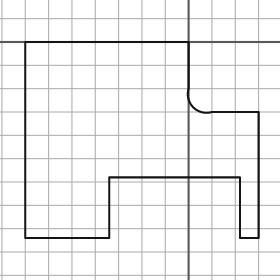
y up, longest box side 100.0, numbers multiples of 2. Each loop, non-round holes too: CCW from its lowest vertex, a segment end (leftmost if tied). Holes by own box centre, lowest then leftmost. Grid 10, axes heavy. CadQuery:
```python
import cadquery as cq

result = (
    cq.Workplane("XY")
    .moveTo(-70.0, -84.0)
    .lineTo(-34.0, -84.0)
    .lineTo(-34.0, -58.0)
    .lineTo(22.0, -58.0)
    .lineTo(22.0, -84.0)
    .lineTo(30.0, -84.0)
    .lineTo(30.0, -30.0)
    .lineTo(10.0, -30.0)
    .threePointArc((2.0, -28.0), (0.0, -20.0))
    .lineTo(0.0, 0.0)
    .lineTo(-70.0, 0.0)
    .close()
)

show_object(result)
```